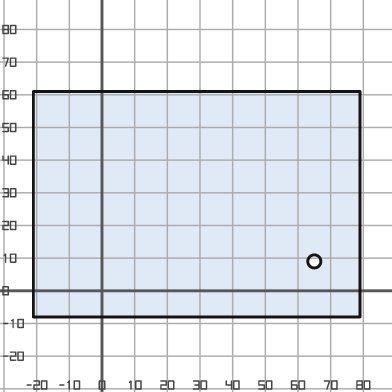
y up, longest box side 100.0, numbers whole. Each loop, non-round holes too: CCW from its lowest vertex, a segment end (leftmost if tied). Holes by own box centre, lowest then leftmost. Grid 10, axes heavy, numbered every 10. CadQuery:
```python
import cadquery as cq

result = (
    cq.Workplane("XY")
    .moveTo(-21.0, -8.0)
    .lineTo(79.0, -8.0)
    .lineTo(79.0, 61.0)
    .lineTo(-21.0, 61.0)
    .close()
    .moveTo(65.0, 9.0)
    .circle(2.0)
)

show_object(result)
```